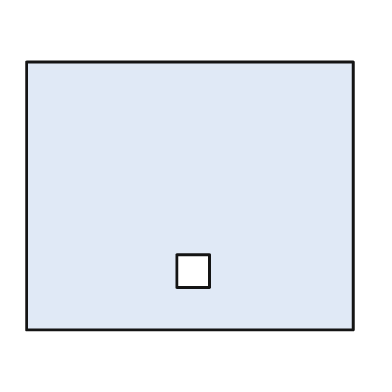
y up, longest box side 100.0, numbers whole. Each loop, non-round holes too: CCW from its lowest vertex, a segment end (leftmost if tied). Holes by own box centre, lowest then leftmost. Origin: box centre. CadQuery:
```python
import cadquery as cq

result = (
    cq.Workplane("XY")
    .moveTo(-50.0, -41.0)
    .lineTo(50.0, -41.0)
    .lineTo(50.0, 41.0)
    .lineTo(-50.0, 41.0)
    .close()
    .moveTo(-4.0, -28.0)
    .lineTo(6.0, -28.0)
    .lineTo(6.0, -18.0)
    .lineTo(-4.0, -18.0)
    .close()
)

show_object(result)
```